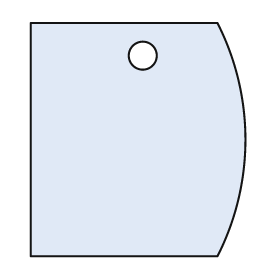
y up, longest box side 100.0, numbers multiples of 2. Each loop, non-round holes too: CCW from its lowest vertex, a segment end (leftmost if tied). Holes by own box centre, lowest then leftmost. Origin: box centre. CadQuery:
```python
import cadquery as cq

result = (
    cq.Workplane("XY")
    .moveTo(-46.0, -50.0)
    .lineTo(34.0, -50.0)
    .threePointArc((46.0, 0.0), (34.0, 50.0))
    .lineTo(-46.0, 50.0)
    .close()
    .moveTo(2.0, 36.0)
    .circle(6.0)
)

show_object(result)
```